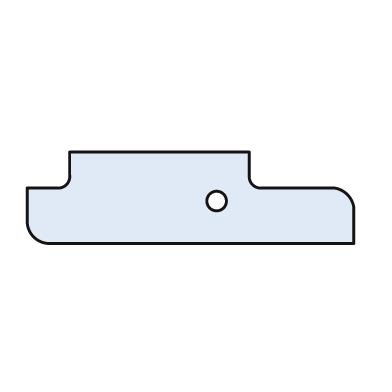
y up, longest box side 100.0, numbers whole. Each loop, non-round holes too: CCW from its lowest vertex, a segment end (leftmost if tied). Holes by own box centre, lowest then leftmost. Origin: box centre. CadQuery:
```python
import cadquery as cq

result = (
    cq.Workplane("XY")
    .moveTo(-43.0, -14.0)
    .lineTo(50.0, -14.0)
    .lineTo(50.0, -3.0)
    .threePointArc((48.0, 1.0), (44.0, 3.0))
    .lineTo(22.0, 3.0)
    .threePointArc((19.0, 4.0), (18.0, 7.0))
    .lineTo(18.0, 14.0)
    .lineTo(-37.0, 14.0)
    .lineTo(-37.0, 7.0)
    .threePointArc((-38.0, 4.0), (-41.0, 3.0))
    .lineTo(-50.0, 3.0)
    .lineTo(-50.0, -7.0)
    .threePointArc((-48.0, -12.0), (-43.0, -14.0))
    .close()
    .moveTo(8.0, -1.0)
    .circle(3.0)
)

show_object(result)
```